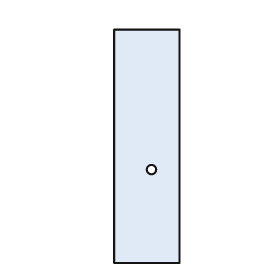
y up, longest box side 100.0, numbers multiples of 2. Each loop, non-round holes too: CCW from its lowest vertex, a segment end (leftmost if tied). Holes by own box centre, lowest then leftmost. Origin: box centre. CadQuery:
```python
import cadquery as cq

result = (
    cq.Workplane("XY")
    .moveTo(-14.0, -50.0)
    .lineTo(14.0, -50.0)
    .lineTo(14.0, 50.0)
    .lineTo(-14.0, 50.0)
    .close()
    .moveTo(2.0, -10.0)
    .circle(2.0)
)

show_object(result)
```